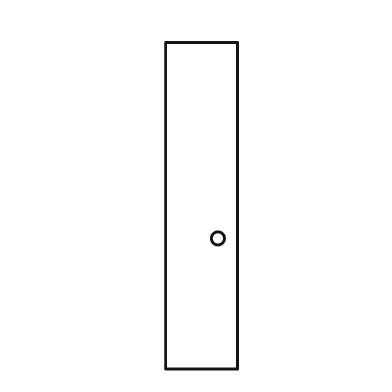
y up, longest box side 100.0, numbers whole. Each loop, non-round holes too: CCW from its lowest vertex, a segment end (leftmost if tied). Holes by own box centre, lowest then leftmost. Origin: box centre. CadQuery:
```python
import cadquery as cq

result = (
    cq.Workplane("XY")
    .moveTo(-11.0, -50.0)
    .lineTo(11.0, -50.0)
    .lineTo(11.0, 50.0)
    .lineTo(-11.0, 50.0)
    .close()
    .moveTo(5.0, -10.0)
    .circle(2.0)
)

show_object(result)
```